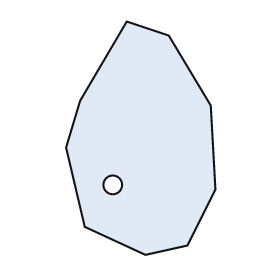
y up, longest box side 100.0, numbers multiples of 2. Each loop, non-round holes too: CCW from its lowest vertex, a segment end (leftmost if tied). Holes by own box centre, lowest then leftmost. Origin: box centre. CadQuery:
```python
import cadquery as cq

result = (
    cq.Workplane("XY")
    .moveTo(2.0, -50.0)
    .lineTo(20.0, -46.0)
    .lineTo(32.0, -22.0)
    .lineTo(30.0, 14.0)
    .lineTo(12.0, 44.0)
    .lineTo(-6.0, 50.0)
    .lineTo(-26.0, 16.0)
    .lineTo(-32.0, -4.0)
    .lineTo(-24.0, -38.0)
    .close()
    .moveTo(-12.0, -20.0)
    .circle(4.0)
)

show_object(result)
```